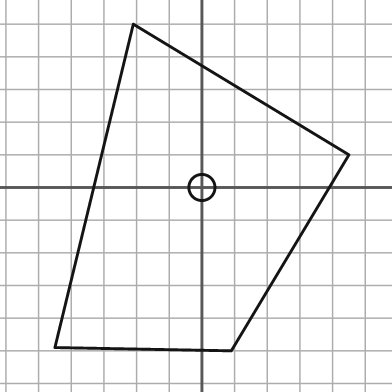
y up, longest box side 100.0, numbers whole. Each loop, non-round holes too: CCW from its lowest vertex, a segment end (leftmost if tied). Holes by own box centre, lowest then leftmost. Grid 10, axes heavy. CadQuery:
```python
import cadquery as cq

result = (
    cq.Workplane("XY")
    .moveTo(9.0, -50.0)
    .lineTo(45.0, 10.0)
    .lineTo(-21.0, 50.0)
    .lineTo(-45.0, -49.0)
    .close()
    .moveTo(0.0, 0.0)
    .circle(4.0)
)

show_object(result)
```